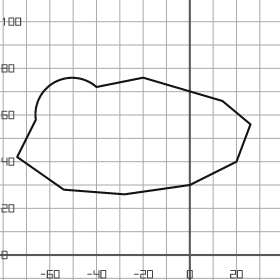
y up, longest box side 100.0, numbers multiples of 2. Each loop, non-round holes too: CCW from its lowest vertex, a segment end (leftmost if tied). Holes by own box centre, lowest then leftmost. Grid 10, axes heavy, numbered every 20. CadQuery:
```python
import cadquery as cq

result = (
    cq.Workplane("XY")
    .moveTo(-28.0, 26.0)
    .lineTo(0.0, 30.0)
    .lineTo(20.0, 40.0)
    .lineTo(26.0, 56.0)
    .lineTo(14.0, 66.0)
    .lineTo(-20.0, 76.0)
    .lineTo(-40.0, 72.0)
    .threePointArc((-58.0, 74.0), (-66.0, 58.0))
    .lineTo(-74.0, 42.0)
    .lineTo(-54.0, 28.0)
    .close()
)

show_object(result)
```